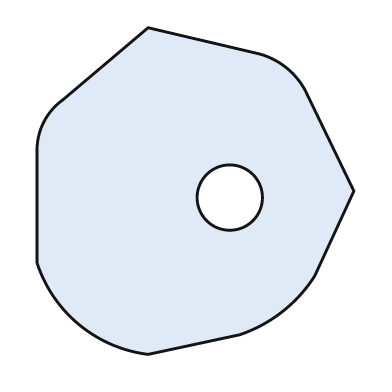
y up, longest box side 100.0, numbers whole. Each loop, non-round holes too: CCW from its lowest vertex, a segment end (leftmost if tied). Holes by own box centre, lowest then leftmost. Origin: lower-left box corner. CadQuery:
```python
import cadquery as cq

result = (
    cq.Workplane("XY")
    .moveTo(34.0, 0.0)
    .lineTo(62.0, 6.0)
    .threePointArc((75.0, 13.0), (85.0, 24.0))
    .lineTo(97.0, 50.0)
    .lineTo(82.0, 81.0)
    .threePointArc((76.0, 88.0), (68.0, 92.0))
    .lineTo(34.0, 100.0)
    .lineTo(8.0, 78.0)
    .threePointArc((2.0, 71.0), (0.0, 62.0))
    .lineTo(0.0, 28.0)
    .threePointArc((13.0, 9.0), (34.0, 0.0))
    .close()
    .moveTo(59.0, 48.0)
    .circle(10.0)
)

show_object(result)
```